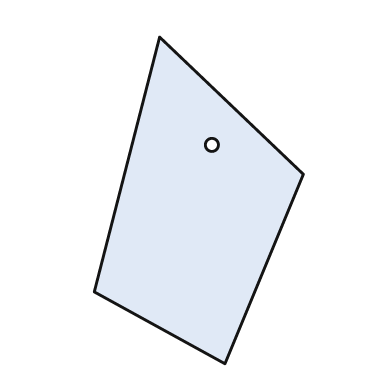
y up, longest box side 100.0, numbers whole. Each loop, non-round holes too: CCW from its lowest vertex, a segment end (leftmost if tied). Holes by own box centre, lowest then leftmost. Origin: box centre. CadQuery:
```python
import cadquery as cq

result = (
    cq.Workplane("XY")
    .moveTo(8.0, -50.0)
    .lineTo(32.0, 8.0)
    .lineTo(-12.0, 50.0)
    .lineTo(-32.0, -28.0)
    .close()
    .moveTo(4.0, 17.0)
    .circle(2.0)
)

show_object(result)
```